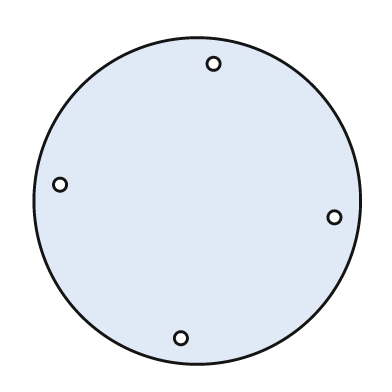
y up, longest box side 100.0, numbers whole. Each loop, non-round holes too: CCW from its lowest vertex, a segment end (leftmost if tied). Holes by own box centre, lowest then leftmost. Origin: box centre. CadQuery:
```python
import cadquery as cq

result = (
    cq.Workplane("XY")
    .moveTo(0.0, 0.0)
    .circle(50.0)
    .moveTo(-5.0, -42.0)
    .circle(2.0)
    .moveTo(42.0, -5.0)
    .circle(2.0)
    .moveTo(-42.0, 5.0)
    .circle(2.0)
    .moveTo(5.0, 42.0)
    .circle(2.0)
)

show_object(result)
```